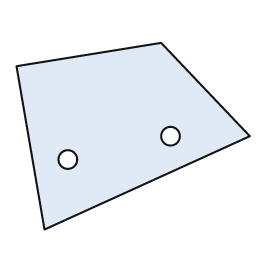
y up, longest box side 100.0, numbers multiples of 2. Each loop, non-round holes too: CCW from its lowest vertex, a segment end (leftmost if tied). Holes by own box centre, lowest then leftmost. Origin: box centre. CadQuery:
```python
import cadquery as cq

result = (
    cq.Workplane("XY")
    .moveTo(-38.0, -40.0)
    .lineTo(50.0, 0.0)
    .lineTo(12.0, 40.0)
    .lineTo(-50.0, 30.0)
    .close()
    .moveTo(-28.0, -10.0)
    .circle(4.0)
    .moveTo(16.0, 0.0)
    .circle(4.0)
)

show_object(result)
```